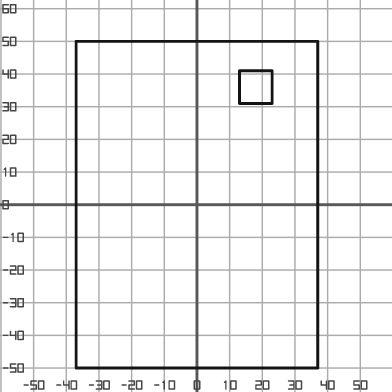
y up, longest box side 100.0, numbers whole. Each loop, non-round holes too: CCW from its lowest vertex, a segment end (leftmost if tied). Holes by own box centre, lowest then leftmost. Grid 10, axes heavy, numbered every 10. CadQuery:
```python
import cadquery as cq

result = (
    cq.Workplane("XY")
    .moveTo(-37.0, -50.0)
    .lineTo(37.0, -50.0)
    .lineTo(37.0, 50.0)
    .lineTo(-37.0, 50.0)
    .close()
    .moveTo(13.0, 31.0)
    .lineTo(23.0, 31.0)
    .lineTo(23.0, 41.0)
    .lineTo(13.0, 41.0)
    .close()
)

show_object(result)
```